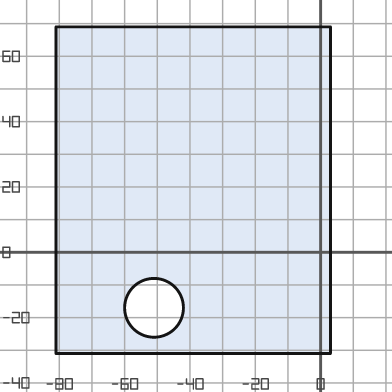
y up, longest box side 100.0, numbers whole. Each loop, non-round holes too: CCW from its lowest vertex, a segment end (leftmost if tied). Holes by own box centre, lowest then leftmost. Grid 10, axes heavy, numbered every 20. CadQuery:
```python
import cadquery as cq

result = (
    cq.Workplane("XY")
    .moveTo(-81.0, -31.0)
    .lineTo(3.0, -31.0)
    .lineTo(3.0, 69.0)
    .lineTo(-81.0, 69.0)
    .close()
    .moveTo(-51.0, -17.0)
    .circle(9.0)
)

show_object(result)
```